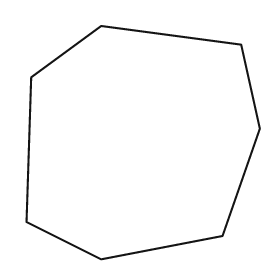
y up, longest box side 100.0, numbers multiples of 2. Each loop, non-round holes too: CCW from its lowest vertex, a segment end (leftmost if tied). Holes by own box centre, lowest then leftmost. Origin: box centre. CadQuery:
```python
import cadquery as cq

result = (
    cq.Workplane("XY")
    .moveTo(-18.0, -50.0)
    .lineTo(34.0, -40.0)
    .lineTo(50.0, 6.0)
    .lineTo(42.0, 42.0)
    .lineTo(-18.0, 50.0)
    .lineTo(-48.0, 28.0)
    .lineTo(-50.0, -34.0)
    .close()
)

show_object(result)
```